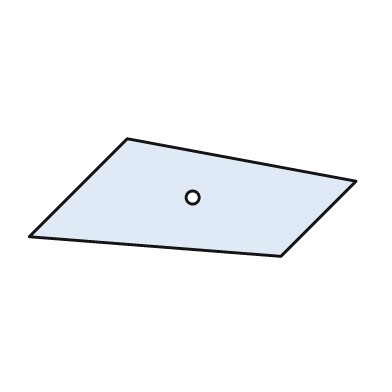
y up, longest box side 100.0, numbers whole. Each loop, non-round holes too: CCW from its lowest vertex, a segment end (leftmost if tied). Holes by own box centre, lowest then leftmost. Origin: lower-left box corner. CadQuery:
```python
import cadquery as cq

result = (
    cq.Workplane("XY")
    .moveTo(77.0, 0.0)
    .lineTo(100.0, 23.0)
    .lineTo(30.0, 36.0)
    .lineTo(0.0, 6.0)
    .close()
    .moveTo(50.0, 18.0)
    .circle(2.0)
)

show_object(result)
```